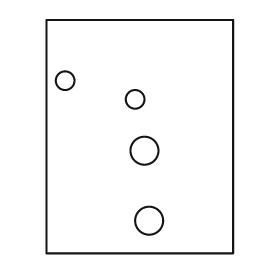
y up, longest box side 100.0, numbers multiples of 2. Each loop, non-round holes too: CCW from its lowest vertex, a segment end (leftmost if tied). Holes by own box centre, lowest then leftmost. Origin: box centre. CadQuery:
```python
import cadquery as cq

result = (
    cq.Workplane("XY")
    .moveTo(-40.0, -50.0)
    .lineTo(40.0, -50.0)
    .lineTo(40.0, 50.0)
    .lineTo(-40.0, 50.0)
    .close()
    .moveTo(4.0, -36.0)
    .circle(6.0)
    .moveTo(2.0, -6.0)
    .circle(6.0)
    .moveTo(-2.0, 16.0)
    .circle(4.0)
    .moveTo(-32.0, 24.0)
    .circle(4.0)
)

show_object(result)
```